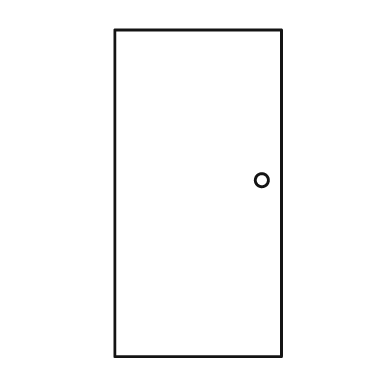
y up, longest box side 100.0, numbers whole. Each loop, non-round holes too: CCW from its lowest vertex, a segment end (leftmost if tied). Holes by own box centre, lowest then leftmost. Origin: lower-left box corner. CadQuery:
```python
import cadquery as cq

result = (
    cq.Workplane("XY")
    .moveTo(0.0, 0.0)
    .lineTo(51.0, 0.0)
    .lineTo(51.0, 100.0)
    .lineTo(0.0, 100.0)
    .close()
    .moveTo(45.0, 54.0)
    .circle(2.0)
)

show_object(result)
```